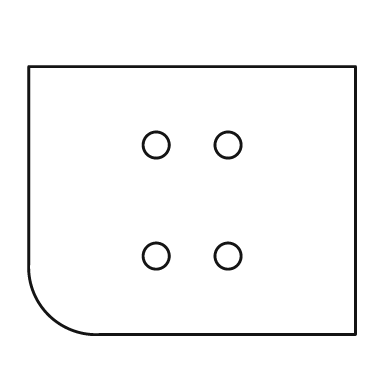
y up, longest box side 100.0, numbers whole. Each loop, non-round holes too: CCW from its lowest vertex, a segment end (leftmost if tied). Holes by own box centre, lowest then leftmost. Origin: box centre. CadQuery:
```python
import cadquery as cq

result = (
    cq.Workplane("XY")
    .moveTo(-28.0, -41.0)
    .lineTo(50.0, -41.0)
    .lineTo(50.0, 41.0)
    .lineTo(-50.0, 41.0)
    .lineTo(-50.0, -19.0)
    .threePointArc((-44.0, -35.0), (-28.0, -41.0))
    .close()
    .moveTo(-11.0, -17.0)
    .circle(4.0)
    .moveTo(11.0, -17.0)
    .circle(4.0)
    .moveTo(-11.0, 17.0)
    .circle(4.0)
    .moveTo(11.0, 17.0)
    .circle(4.0)
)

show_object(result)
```